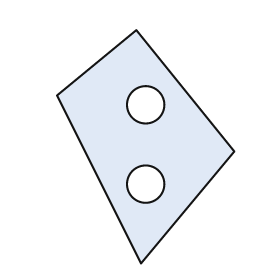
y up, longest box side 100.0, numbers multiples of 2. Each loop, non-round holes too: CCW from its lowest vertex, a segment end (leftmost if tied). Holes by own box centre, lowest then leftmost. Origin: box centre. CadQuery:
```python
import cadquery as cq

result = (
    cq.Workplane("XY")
    .moveTo(-2.0, -50.0)
    .lineTo(38.0, -2.0)
    .lineTo(-4.0, 50.0)
    .lineTo(-38.0, 22.0)
    .close()
    .moveTo(0.0, -16.0)
    .circle(8.0)
    .moveTo(0.0, 18.0)
    .circle(8.0)
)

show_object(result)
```